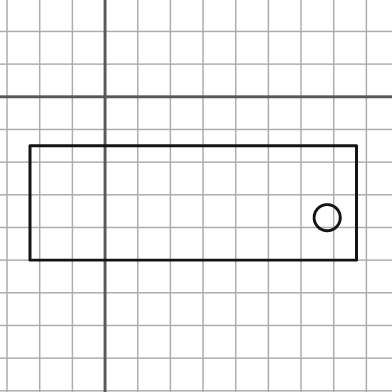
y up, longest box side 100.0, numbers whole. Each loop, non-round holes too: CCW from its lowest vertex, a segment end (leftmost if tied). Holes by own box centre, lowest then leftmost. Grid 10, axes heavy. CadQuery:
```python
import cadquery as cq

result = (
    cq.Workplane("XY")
    .moveTo(-23.0, -50.0)
    .lineTo(77.0, -50.0)
    .lineTo(77.0, -15.0)
    .lineTo(-23.0, -15.0)
    .close()
    .moveTo(68.0, -37.0)
    .circle(4.0)
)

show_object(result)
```